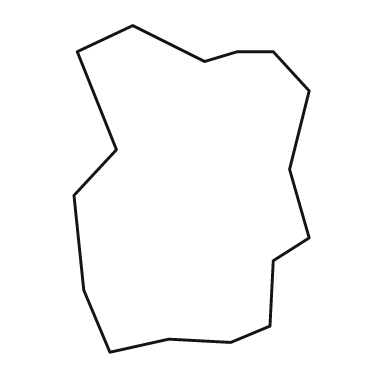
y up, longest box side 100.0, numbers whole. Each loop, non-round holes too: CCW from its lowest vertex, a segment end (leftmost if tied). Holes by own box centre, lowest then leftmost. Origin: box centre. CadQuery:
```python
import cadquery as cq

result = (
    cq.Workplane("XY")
    .moveTo(-25.0, -50.0)
    .lineTo(-7.0, -46.0)
    .lineTo(12.0, -47.0)
    .lineTo(24.0, -42.0)
    .lineTo(25.0, -22.0)
    .lineTo(36.0, -15.0)
    .lineTo(30.0, 6.0)
    .lineTo(36.0, 30.0)
    .lineTo(25.0, 42.0)
    .lineTo(14.0, 42.0)
    .lineTo(4.0, 39.0)
    .lineTo(-18.0, 50.0)
    .lineTo(-35.0, 42.0)
    .lineTo(-23.0, 12.0)
    .lineTo(-36.0, -2.0)
    .lineTo(-33.0, -31.0)
    .close()
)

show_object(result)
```